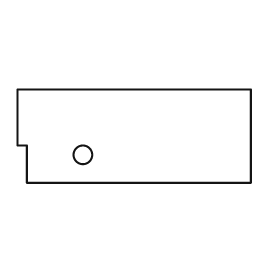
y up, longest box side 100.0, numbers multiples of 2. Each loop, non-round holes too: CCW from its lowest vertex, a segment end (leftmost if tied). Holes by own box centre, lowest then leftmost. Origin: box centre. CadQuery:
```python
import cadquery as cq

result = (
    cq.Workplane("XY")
    .moveTo(-46.0, -20.0)
    .lineTo(50.0, -20.0)
    .lineTo(50.0, 20.0)
    .lineTo(-50.0, 20.0)
    .lineTo(-50.0, -4.0)
    .lineTo(-46.0, -4.0)
    .close()
    .moveTo(-22.0, -8.0)
    .circle(4.0)
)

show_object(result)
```